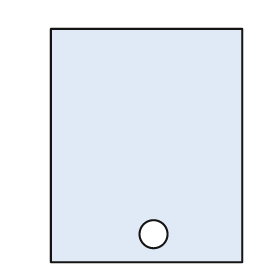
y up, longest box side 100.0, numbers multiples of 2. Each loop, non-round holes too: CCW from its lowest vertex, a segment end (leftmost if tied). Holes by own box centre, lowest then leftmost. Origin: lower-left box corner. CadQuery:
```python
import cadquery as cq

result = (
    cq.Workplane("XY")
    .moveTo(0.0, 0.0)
    .lineTo(82.0, 0.0)
    .lineTo(82.0, 100.0)
    .lineTo(0.0, 100.0)
    .close()
    .moveTo(44.0, 12.0)
    .circle(6.0)
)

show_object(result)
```